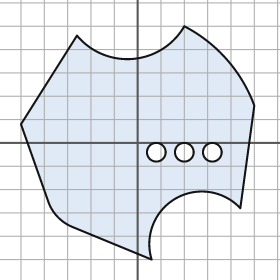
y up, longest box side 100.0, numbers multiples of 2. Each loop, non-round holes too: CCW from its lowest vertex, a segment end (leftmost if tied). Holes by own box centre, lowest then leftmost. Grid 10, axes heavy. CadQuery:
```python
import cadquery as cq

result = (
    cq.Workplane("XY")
    .moveTo(6.0, -50.0)
    .threePointArc((16.0, -24.0), (44.0, -28.0))
    .lineTo(50.0, 16.0)
    .threePointArc((38.0, 36.0), (20.0, 50.0))
    .threePointArc((-2.0, 36.0), (-26.0, 46.0))
    .lineTo(-50.0, 8.0)
    .lineTo(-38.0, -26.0)
    .threePointArc((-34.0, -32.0), (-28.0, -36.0))
    .close()
    .moveTo(8.0, -4.0)
    .circle(4.0)
    .moveTo(20.0, -4.0)
    .circle(4.0)
    .moveTo(32.0, -4.0)
    .circle(4.0)
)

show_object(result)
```